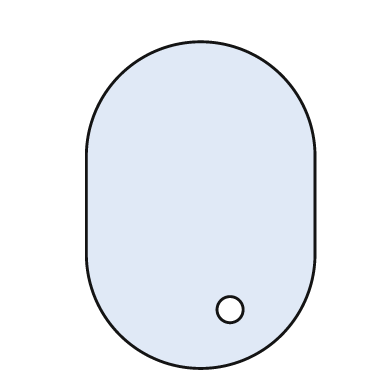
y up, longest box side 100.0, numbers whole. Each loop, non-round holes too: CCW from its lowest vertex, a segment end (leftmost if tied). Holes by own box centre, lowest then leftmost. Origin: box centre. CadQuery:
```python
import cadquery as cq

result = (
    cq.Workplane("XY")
    .moveTo(-35.0, -15.0)
    .threePointArc((0.0, -50.0), (35.0, -15.0))
    .lineTo(35.0, 15.0)
    .threePointArc((0.0, 50.0), (-35.0, 15.0))
    .close()
    .moveTo(9.0, -32.0)
    .circle(4.0)
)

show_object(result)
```